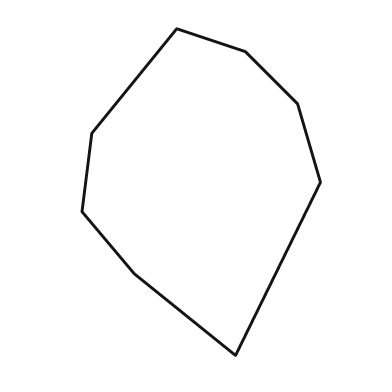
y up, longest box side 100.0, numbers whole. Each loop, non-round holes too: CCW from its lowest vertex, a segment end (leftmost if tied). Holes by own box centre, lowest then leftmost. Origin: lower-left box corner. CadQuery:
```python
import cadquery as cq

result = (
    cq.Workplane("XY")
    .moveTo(47.0, 0.0)
    .lineTo(73.0, 53.0)
    .lineTo(66.0, 77.0)
    .lineTo(50.0, 93.0)
    .lineTo(29.0, 100.0)
    .lineTo(3.0, 68.0)
    .lineTo(0.0, 44.0)
    .lineTo(16.0, 25.0)
    .close()
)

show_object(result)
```